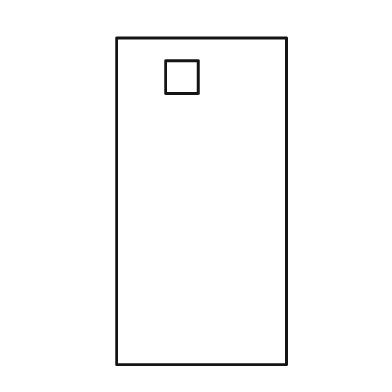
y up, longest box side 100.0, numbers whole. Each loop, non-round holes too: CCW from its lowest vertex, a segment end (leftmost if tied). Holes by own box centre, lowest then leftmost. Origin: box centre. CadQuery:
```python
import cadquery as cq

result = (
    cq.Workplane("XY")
    .moveTo(-26.0, -50.0)
    .lineTo(26.0, -50.0)
    .lineTo(26.0, 50.0)
    .lineTo(-26.0, 50.0)
    .close()
    .moveTo(-11.0, 33.0)
    .lineTo(-1.0, 33.0)
    .lineTo(-1.0, 43.0)
    .lineTo(-11.0, 43.0)
    .close()
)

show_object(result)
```